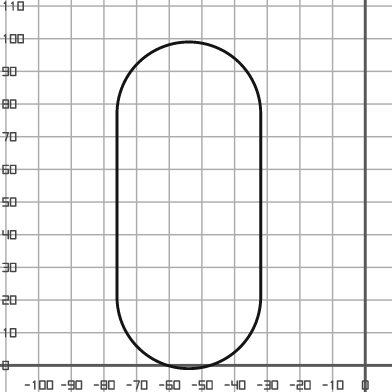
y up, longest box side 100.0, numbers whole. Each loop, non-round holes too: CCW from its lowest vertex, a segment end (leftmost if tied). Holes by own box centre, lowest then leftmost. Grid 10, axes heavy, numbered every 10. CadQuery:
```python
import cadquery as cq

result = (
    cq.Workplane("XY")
    .moveTo(-76.0, 21.0)
    .threePointArc((-54.0, -1.0), (-32.0, 21.0))
    .lineTo(-32.0, 77.0)
    .threePointArc((-54.0, 99.0), (-76.0, 77.0))
    .close()
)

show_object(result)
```